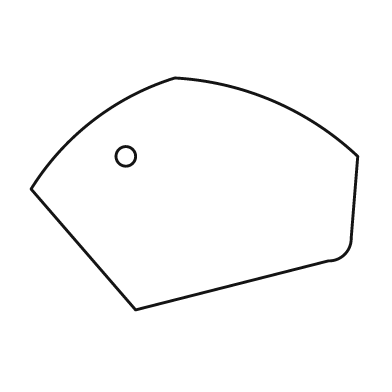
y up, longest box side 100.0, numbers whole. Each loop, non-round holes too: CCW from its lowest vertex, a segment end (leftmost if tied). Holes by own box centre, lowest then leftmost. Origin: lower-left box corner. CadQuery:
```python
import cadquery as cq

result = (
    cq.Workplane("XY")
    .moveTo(32.0, 0.0)
    .lineTo(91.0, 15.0)
    .threePointArc((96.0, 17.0), (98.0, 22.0))
    .lineTo(100.0, 47.0)
    .threePointArc((74.0, 64.0), (44.0, 71.0))
    .threePointArc((19.0, 58.0), (0.0, 37.0))
    .close()
    .moveTo(29.0, 47.0)
    .circle(3.0)
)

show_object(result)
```